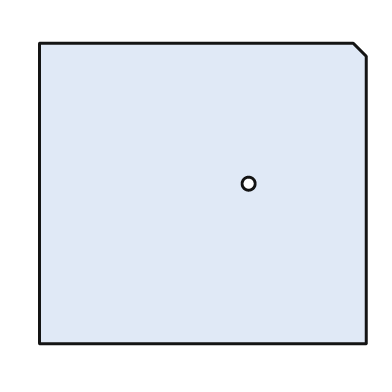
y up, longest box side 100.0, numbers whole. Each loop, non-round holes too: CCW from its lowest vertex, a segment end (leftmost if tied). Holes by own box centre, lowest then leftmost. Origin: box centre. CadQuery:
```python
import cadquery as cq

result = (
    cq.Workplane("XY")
    .moveTo(-50.0, -46.0)
    .lineTo(50.0, -46.0)
    .lineTo(50.0, 42.0)
    .lineTo(46.0, 46.0)
    .lineTo(-50.0, 46.0)
    .close()
    .moveTo(14.0, 3.0)
    .circle(2.0)
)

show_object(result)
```